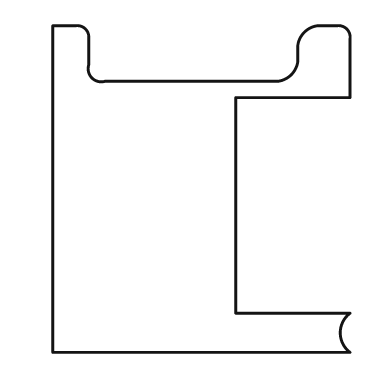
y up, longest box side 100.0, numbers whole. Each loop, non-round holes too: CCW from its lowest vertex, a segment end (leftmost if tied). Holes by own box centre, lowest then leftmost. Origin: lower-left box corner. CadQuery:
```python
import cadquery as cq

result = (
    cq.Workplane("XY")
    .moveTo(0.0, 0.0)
    .lineTo(91.0, 0.0)
    .threePointArc((88.0, 6.0), (91.0, 12.0))
    .lineTo(56.0, 12.0)
    .lineTo(56.0, 78.0)
    .lineTo(91.0, 78.0)
    .lineTo(91.0, 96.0)
    .threePointArc((90.0, 99.0), (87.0, 100.0))
    .lineTo(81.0, 100.0)
    .threePointArc((77.0, 98.0), (75.0, 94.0))
    .lineTo(75.0, 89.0)
    .threePointArc((73.0, 85.0), (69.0, 83.0))
    .lineTo(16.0, 83.0)
    .threePointArc((12.0, 84.0), (11.0, 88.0))
    .lineTo(11.0, 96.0)
    .threePointArc((10.0, 99.0), (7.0, 100.0))
    .lineTo(0.0, 100.0)
    .close()
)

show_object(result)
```